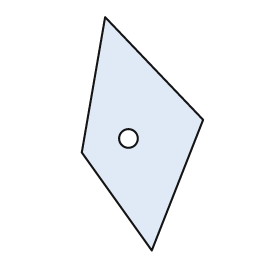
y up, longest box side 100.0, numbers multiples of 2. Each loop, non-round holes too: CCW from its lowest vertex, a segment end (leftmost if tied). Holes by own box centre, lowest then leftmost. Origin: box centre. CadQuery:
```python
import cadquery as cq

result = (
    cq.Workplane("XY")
    .moveTo(4.0, -50.0)
    .lineTo(26.0, 6.0)
    .lineTo(-16.0, 50.0)
    .lineTo(-26.0, -8.0)
    .close()
    .moveTo(-6.0, -2.0)
    .circle(4.0)
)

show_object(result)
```